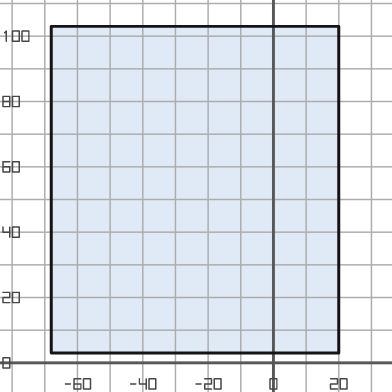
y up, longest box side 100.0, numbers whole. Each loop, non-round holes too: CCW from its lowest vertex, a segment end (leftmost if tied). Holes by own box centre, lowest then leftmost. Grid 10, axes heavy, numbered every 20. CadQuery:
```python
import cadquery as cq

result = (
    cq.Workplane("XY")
    .moveTo(-68.0, 3.0)
    .lineTo(20.0, 3.0)
    .lineTo(20.0, 103.0)
    .lineTo(-68.0, 103.0)
    .close()
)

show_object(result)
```